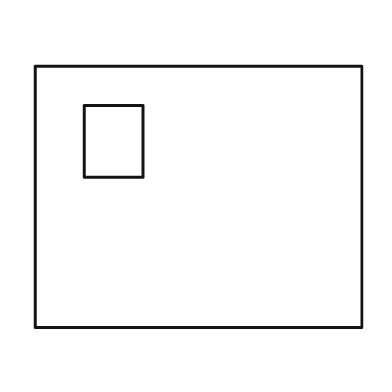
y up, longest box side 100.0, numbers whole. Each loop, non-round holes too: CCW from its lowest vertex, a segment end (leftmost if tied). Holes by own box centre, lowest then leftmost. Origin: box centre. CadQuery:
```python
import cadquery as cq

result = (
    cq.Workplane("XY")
    .moveTo(-50.0, -40.0)
    .lineTo(50.0, -40.0)
    .lineTo(50.0, 40.0)
    .lineTo(-50.0, 40.0)
    .close()
    .moveTo(-35.0, 6.0)
    .lineTo(-17.0, 6.0)
    .lineTo(-17.0, 28.0)
    .lineTo(-35.0, 28.0)
    .close()
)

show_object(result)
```